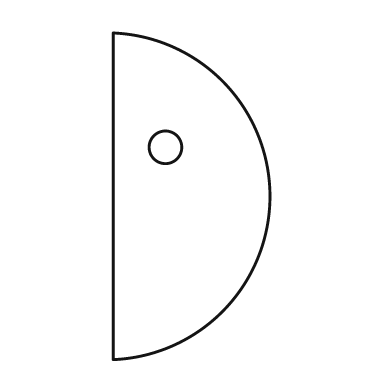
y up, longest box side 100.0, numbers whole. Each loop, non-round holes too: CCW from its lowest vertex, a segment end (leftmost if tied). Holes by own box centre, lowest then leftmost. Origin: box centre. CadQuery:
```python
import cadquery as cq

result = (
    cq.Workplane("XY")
    .moveTo(-24.0, -50.0)
    .threePointArc((24.0, 0.0), (-24.0, 50.0))
    .close()
    .moveTo(-8.0, 15.0)
    .circle(5.0)
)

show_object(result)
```